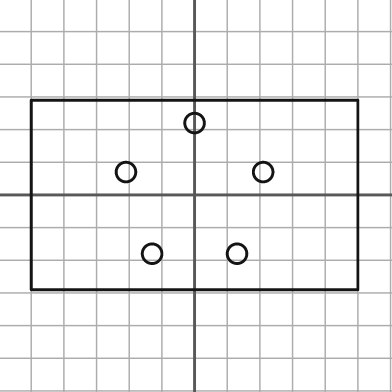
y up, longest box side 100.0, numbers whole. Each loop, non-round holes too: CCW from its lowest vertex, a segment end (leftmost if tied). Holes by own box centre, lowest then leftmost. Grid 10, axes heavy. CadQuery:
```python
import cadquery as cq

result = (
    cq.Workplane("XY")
    .moveTo(-50.0, -29.0)
    .lineTo(50.0, -29.0)
    .lineTo(50.0, 29.0)
    .lineTo(-50.0, 29.0)
    .close()
    .moveTo(-13.0, -18.0)
    .circle(3.0)
    .moveTo(13.0, -18.0)
    .circle(3.0)
    .moveTo(-21.0, 7.0)
    .circle(3.0)
    .moveTo(21.0, 7.0)
    .circle(3.0)
    .moveTo(0.0, 22.0)
    .circle(3.0)
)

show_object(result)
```